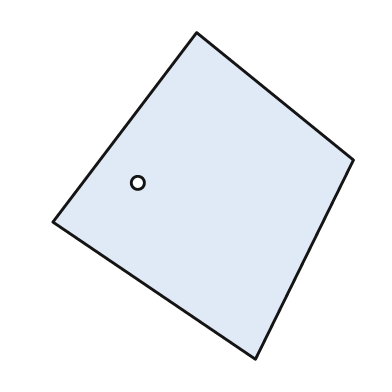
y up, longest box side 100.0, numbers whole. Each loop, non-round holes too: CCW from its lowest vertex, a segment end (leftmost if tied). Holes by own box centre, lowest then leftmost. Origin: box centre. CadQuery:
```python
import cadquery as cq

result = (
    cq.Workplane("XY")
    .moveTo(16.0, -50.0)
    .lineTo(46.0, 11.0)
    .lineTo(-2.0, 50.0)
    .lineTo(-46.0, -8.0)
    .close()
    .moveTo(-20.0, 4.0)
    .circle(2.0)
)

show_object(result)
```